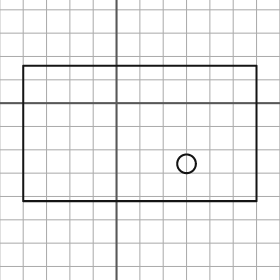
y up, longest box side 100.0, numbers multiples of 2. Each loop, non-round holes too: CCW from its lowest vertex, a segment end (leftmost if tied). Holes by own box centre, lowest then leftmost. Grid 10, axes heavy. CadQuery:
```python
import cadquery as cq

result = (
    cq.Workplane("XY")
    .moveTo(-40.0, -42.0)
    .lineTo(60.0, -42.0)
    .lineTo(60.0, 16.0)
    .lineTo(-40.0, 16.0)
    .close()
    .moveTo(30.0, -26.0)
    .circle(4.0)
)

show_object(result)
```